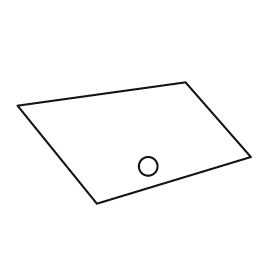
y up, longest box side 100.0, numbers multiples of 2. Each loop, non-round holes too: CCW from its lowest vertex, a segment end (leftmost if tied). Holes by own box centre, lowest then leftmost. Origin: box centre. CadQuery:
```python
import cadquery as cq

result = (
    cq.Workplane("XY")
    .moveTo(-16.0, -26.0)
    .lineTo(50.0, -6.0)
    .lineTo(22.0, 26.0)
    .lineTo(-50.0, 16.0)
    .close()
    .moveTo(6.0, -10.0)
    .circle(4.0)
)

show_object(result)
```